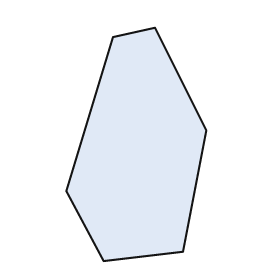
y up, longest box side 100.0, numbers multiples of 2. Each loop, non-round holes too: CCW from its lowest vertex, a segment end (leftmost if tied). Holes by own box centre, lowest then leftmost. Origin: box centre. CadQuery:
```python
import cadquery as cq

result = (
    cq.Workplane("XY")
    .moveTo(-14.0, -50.0)
    .lineTo(20.0, -46.0)
    .lineTo(30.0, 6.0)
    .lineTo(8.0, 50.0)
    .lineTo(-10.0, 46.0)
    .lineTo(-30.0, -20.0)
    .close()
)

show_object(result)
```